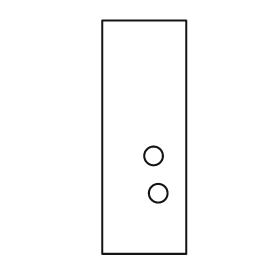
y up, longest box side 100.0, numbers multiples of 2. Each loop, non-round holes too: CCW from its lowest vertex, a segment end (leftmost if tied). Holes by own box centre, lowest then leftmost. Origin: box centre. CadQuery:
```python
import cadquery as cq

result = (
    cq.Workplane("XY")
    .moveTo(-18.0, -50.0)
    .lineTo(18.0, -50.0)
    .lineTo(18.0, 50.0)
    .lineTo(-18.0, 50.0)
    .close()
    .moveTo(6.0, -24.0)
    .circle(4.0)
    .moveTo(4.0, -8.0)
    .circle(4.0)
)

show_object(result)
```